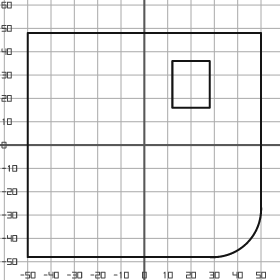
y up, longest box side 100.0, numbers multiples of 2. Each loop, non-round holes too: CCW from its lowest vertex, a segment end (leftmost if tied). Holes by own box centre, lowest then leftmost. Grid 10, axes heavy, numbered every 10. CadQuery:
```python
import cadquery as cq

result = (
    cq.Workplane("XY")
    .moveTo(-50.0, -48.0)
    .lineTo(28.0, -48.0)
    .threePointArc((44.0, -42.0), (50.0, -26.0))
    .lineTo(50.0, 48.0)
    .lineTo(-50.0, 48.0)
    .close()
    .moveTo(12.0, 16.0)
    .lineTo(28.0, 16.0)
    .lineTo(28.0, 36.0)
    .lineTo(12.0, 36.0)
    .close()
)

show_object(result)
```